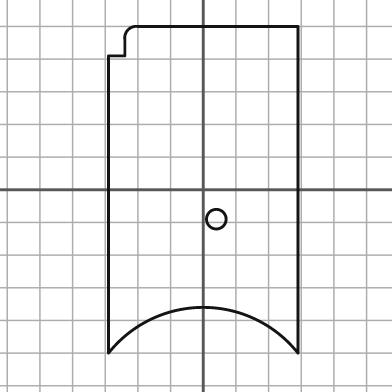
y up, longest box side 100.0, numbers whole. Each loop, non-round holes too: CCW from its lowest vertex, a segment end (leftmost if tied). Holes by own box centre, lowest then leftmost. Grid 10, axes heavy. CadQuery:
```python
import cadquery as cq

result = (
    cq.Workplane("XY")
    .moveTo(-29.0, -50.0)
    .threePointArc((0.0, -36.0), (29.0, -50.0))
    .lineTo(29.0, 50.0)
    .lineTo(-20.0, 50.0)
    .threePointArc((-23.0, 49.0), (-24.0, 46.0))
    .lineTo(-24.0, 41.0)
    .lineTo(-29.0, 41.0)
    .close()
    .moveTo(4.0, -9.0)
    .circle(3.0)
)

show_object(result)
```